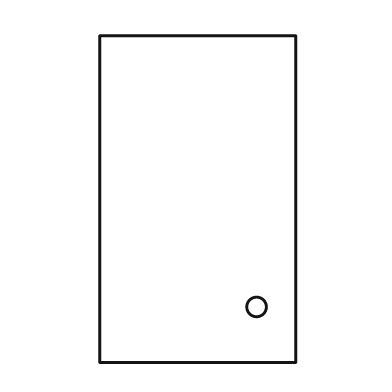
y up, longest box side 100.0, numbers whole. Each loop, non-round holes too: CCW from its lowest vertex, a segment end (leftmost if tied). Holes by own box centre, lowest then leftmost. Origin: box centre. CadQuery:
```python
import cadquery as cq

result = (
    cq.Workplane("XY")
    .moveTo(-30.0, -50.0)
    .lineTo(30.0, -50.0)
    .lineTo(30.0, 50.0)
    .lineTo(-30.0, 50.0)
    .close()
    .moveTo(18.0, -33.0)
    .circle(3.0)
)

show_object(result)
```